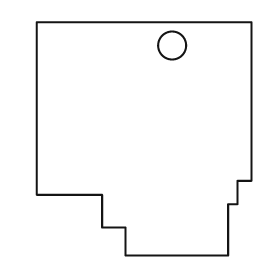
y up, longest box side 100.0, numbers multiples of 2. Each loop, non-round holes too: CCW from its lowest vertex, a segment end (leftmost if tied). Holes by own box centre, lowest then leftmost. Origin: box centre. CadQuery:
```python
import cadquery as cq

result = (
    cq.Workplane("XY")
    .moveTo(-8.0, -50.0)
    .lineTo(36.0, -50.0)
    .lineTo(36.0, -28.0)
    .lineTo(40.0, -28.0)
    .lineTo(40.0, -18.0)
    .lineTo(46.0, -18.0)
    .lineTo(46.0, 50.0)
    .lineTo(-46.0, 50.0)
    .lineTo(-46.0, -24.0)
    .lineTo(-18.0, -24.0)
    .lineTo(-18.0, -38.0)
    .lineTo(-8.0, -38.0)
    .close()
    .moveTo(12.0, 40.0)
    .circle(6.0)
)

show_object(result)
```